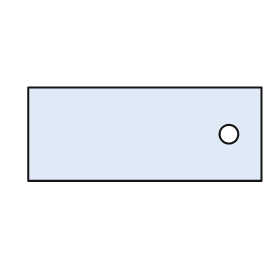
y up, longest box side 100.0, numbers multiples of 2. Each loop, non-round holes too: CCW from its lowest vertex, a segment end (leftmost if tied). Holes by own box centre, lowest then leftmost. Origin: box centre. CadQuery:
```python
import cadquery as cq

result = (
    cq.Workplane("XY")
    .moveTo(-50.0, -20.0)
    .lineTo(50.0, -20.0)
    .lineTo(50.0, 20.0)
    .lineTo(-50.0, 20.0)
    .close()
    .moveTo(36.0, 0.0)
    .circle(4.0)
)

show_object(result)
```